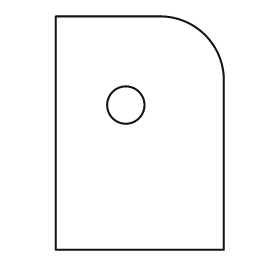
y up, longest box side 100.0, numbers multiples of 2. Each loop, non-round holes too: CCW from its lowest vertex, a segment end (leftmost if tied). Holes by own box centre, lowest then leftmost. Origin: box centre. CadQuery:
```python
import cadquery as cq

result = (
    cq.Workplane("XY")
    .moveTo(-36.0, -50.0)
    .lineTo(36.0, -50.0)
    .lineTo(36.0, 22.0)
    .threePointArc((28.0, 42.0), (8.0, 50.0))
    .lineTo(-36.0, 50.0)
    .close()
    .moveTo(-6.0, 12.0)
    .circle(8.0)
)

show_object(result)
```